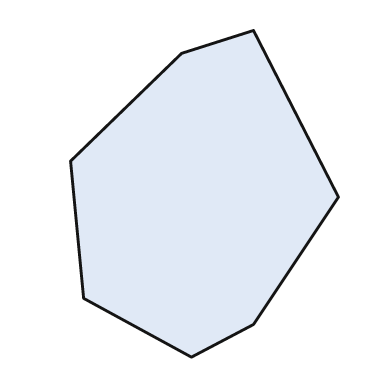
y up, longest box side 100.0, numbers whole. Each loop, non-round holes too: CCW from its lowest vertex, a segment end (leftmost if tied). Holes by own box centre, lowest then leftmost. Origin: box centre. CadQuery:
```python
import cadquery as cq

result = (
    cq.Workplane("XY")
    .moveTo(-4.0, -50.0)
    .lineTo(15.0, -40.0)
    .lineTo(41.0, -1.0)
    .lineTo(15.0, 50.0)
    .lineTo(-7.0, 43.0)
    .lineTo(-41.0, 10.0)
    .lineTo(-37.0, -32.0)
    .close()
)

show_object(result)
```